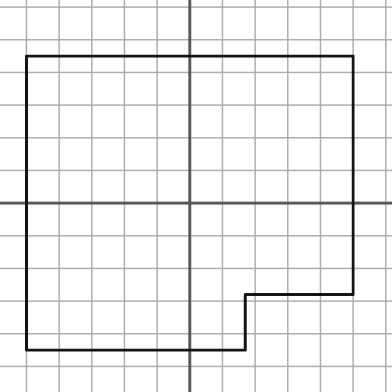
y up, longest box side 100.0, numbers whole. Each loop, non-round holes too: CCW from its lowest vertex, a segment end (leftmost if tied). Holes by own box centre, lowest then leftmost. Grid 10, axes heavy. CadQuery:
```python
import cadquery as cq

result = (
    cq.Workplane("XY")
    .moveTo(-50.0, -45.0)
    .lineTo(17.0, -45.0)
    .lineTo(17.0, -28.0)
    .lineTo(50.0, -28.0)
    .lineTo(50.0, 45.0)
    .lineTo(-50.0, 45.0)
    .close()
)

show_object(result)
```